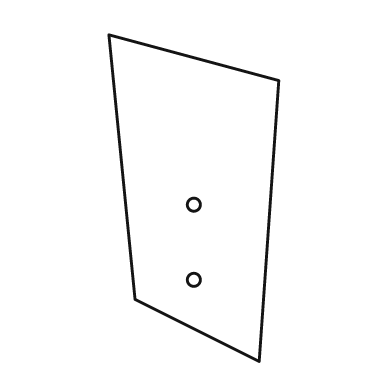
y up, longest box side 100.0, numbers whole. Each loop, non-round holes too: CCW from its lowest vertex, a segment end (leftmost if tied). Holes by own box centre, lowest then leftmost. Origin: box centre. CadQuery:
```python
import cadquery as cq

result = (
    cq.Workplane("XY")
    .moveTo(20.0, -50.0)
    .lineTo(26.0, 36.0)
    .lineTo(-26.0, 50.0)
    .lineTo(-18.0, -31.0)
    .close()
    .moveTo(0.0, -25.0)
    .circle(2.0)
    .moveTo(0.0, -2.0)
    .circle(2.0)
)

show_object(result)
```